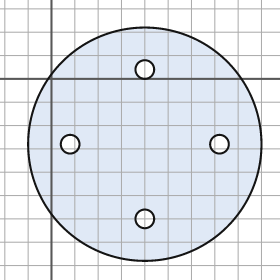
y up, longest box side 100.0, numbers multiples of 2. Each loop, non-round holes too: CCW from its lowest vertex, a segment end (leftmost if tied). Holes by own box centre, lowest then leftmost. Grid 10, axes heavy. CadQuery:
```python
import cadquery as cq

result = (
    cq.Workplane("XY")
    .moveTo(40.0, -28.0)
    .circle(50.0)
    .moveTo(40.0, -60.0)
    .circle(4.0)
    .moveTo(8.0, -28.0)
    .circle(4.0)
    .moveTo(72.0, -28.0)
    .circle(4.0)
    .moveTo(40.0, 4.0)
    .circle(4.0)
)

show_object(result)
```